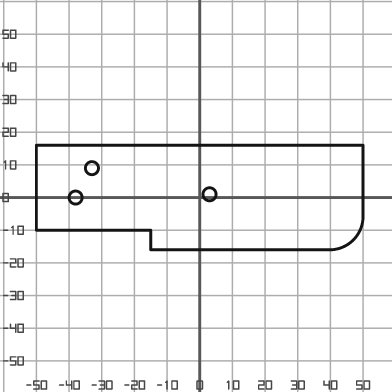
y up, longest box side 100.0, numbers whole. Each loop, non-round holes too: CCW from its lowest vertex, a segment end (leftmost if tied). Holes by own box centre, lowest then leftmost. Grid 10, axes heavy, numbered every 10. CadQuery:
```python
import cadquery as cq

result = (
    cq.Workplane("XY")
    .moveTo(-15.0, -16.0)
    .lineTo(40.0, -16.0)
    .threePointArc((47.0, -13.0), (50.0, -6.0))
    .lineTo(50.0, 16.0)
    .lineTo(-50.0, 16.0)
    .lineTo(-50.0, -10.0)
    .lineTo(-15.0, -10.0)
    .close()
    .moveTo(-38.0, 0.0)
    .circle(2.0)
    .moveTo(3.0, 1.0)
    .circle(2.0)
    .moveTo(-33.0, 9.0)
    .circle(2.0)
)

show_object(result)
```